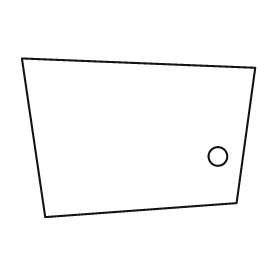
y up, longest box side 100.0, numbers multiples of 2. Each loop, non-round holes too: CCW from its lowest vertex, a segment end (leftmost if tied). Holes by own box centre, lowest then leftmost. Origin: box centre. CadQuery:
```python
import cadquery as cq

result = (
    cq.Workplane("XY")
    .moveTo(-40.0, -34.0)
    .lineTo(42.0, -28.0)
    .lineTo(50.0, 30.0)
    .lineTo(-50.0, 34.0)
    .close()
    .moveTo(34.0, -8.0)
    .circle(4.0)
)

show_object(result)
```